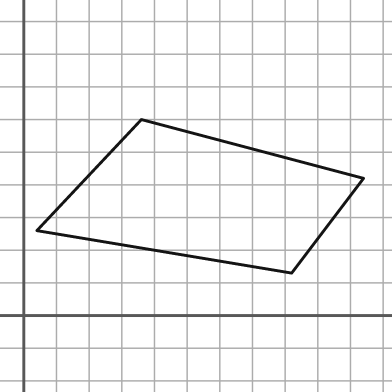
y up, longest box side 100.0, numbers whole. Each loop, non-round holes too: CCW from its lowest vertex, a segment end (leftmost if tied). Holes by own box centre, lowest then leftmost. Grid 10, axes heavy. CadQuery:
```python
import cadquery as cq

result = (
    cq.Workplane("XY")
    .moveTo(82.0, 13.0)
    .lineTo(104.0, 42.0)
    .lineTo(36.0, 60.0)
    .lineTo(4.0, 26.0)
    .close()
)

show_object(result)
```